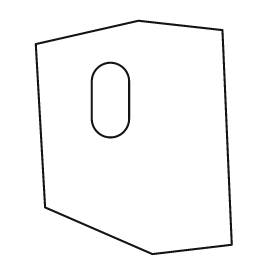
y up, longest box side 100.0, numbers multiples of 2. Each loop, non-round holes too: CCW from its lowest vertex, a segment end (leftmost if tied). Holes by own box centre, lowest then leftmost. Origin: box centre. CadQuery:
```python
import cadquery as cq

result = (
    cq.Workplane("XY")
    .moveTo(8.0, -50.0)
    .lineTo(42.0, -46.0)
    .lineTo(38.0, 46.0)
    .lineTo(2.0, 50.0)
    .lineTo(-42.0, 40.0)
    .lineTo(-38.0, -30.0)
    .close()
    .moveTo(-18.0, 8.0)
    .threePointArc((-10.0, 0.0), (-2.0, 8.0))
    .lineTo(-2.0, 24.0)
    .threePointArc((-10.0, 32.0), (-18.0, 24.0))
    .close()
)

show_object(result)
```